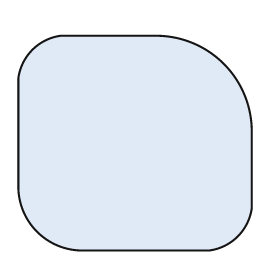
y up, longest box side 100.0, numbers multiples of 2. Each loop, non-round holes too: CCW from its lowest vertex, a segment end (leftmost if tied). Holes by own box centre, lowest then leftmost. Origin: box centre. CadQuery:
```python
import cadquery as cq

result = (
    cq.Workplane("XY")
    .moveTo(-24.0, -46.0)
    .lineTo(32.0, -46.0)
    .threePointArc((44.0, -40.0), (50.0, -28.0))
    .lineTo(50.0, 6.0)
    .threePointArc((38.0, 34.0), (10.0, 46.0))
    .lineTo(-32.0, 46.0)
    .threePointArc((-44.0, 40.0), (-50.0, 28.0))
    .lineTo(-50.0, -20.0)
    .threePointArc((-42.0, -38.0), (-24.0, -46.0))
    .close()
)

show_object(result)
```